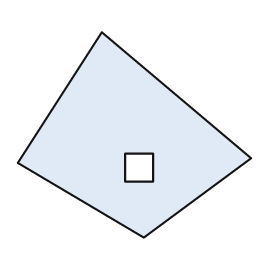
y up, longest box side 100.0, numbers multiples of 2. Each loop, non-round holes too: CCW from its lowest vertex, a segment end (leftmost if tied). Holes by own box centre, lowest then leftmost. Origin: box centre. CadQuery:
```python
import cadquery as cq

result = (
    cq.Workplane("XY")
    .moveTo(4.0, -44.0)
    .lineTo(50.0, -10.0)
    .lineTo(-14.0, 44.0)
    .lineTo(-50.0, -12.0)
    .close()
    .moveTo(-4.0, -20.0)
    .lineTo(8.0, -20.0)
    .lineTo(8.0, -8.0)
    .lineTo(-4.0, -8.0)
    .close()
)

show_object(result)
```